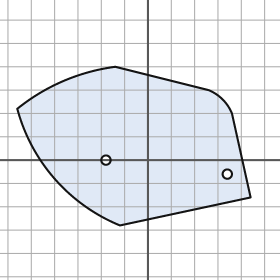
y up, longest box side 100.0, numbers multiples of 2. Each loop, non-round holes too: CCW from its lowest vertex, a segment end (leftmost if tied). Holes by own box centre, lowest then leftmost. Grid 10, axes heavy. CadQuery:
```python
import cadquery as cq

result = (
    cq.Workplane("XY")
    .moveTo(-12.0, -28.0)
    .lineTo(44.0, -16.0)
    .lineTo(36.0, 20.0)
    .threePointArc((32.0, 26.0), (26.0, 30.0))
    .lineTo(-14.0, 40.0)
    .threePointArc((-36.0, 34.0), (-56.0, 22.0))
    .threePointArc((-40.0, -8.0), (-12.0, -28.0))
    .close()
    .moveTo(34.0, -6.0)
    .circle(2.0)
    .moveTo(-18.0, 0.0)
    .circle(2.0)
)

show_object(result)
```